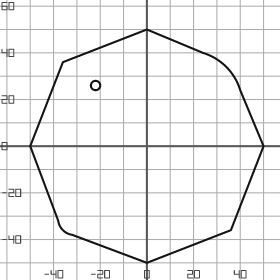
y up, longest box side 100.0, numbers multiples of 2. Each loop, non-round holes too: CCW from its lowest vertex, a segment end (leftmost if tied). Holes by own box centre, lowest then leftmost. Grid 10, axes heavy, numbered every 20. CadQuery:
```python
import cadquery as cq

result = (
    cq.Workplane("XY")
    .moveTo(0.0, -50.0)
    .lineTo(36.0, -36.0)
    .lineTo(50.0, 0.0)
    .lineTo(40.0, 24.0)
    .threePointArc((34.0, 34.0), (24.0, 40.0))
    .lineTo(0.0, 50.0)
    .lineTo(-36.0, 36.0)
    .lineTo(-50.0, 0.0)
    .lineTo(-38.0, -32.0)
    .threePointArc((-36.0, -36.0), (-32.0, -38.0))
    .close()
    .moveTo(-22.0, 26.0)
    .circle(2.0)
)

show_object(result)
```